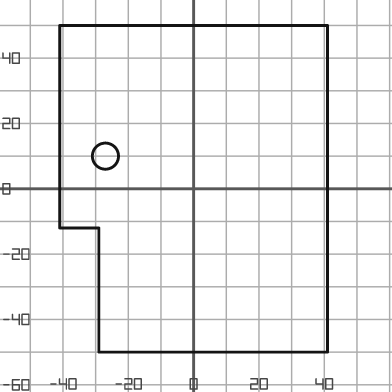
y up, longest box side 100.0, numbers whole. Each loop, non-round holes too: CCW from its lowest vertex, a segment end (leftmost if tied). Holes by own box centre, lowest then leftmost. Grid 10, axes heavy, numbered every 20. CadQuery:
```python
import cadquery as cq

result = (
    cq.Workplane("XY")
    .moveTo(-29.0, -50.0)
    .lineTo(41.0, -50.0)
    .lineTo(41.0, 50.0)
    .lineTo(-41.0, 50.0)
    .lineTo(-41.0, -12.0)
    .lineTo(-29.0, -12.0)
    .close()
    .moveTo(-27.0, 10.0)
    .circle(4.0)
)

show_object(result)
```